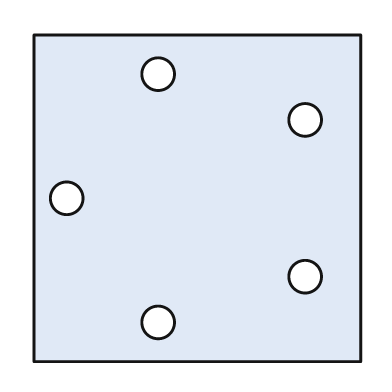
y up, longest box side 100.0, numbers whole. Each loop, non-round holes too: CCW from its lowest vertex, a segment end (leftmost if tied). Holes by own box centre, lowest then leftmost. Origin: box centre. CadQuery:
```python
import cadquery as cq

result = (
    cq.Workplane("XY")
    .moveTo(-50.0, -50.0)
    .lineTo(50.0, -50.0)
    .lineTo(50.0, 50.0)
    .lineTo(-50.0, 50.0)
    .close()
    .moveTo(-12.0, -38.0)
    .circle(5.0)
    .moveTo(33.0, -24.0)
    .circle(5.0)
    .moveTo(-40.0, 0.0)
    .circle(5.0)
    .moveTo(33.0, 24.0)
    .circle(5.0)
    .moveTo(-12.0, 38.0)
    .circle(5.0)
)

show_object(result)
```